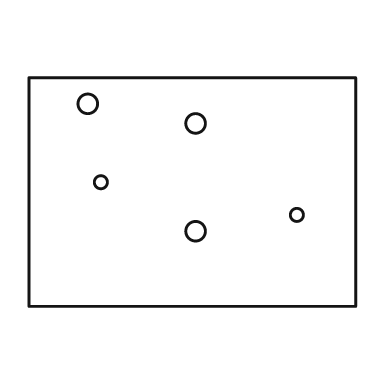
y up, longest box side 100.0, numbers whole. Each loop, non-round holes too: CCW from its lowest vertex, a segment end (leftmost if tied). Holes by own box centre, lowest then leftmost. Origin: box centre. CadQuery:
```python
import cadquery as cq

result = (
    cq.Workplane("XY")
    .moveTo(-50.0, -35.0)
    .lineTo(50.0, -35.0)
    .lineTo(50.0, 35.0)
    .lineTo(-50.0, 35.0)
    .close()
    .moveTo(1.0, -12.0)
    .circle(3.0)
    .moveTo(32.0, -7.0)
    .circle(2.0)
    .moveTo(-28.0, 3.0)
    .circle(2.0)
    .moveTo(1.0, 21.0)
    .circle(3.0)
    .moveTo(-32.0, 27.0)
    .circle(3.0)
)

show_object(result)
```